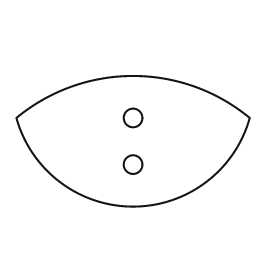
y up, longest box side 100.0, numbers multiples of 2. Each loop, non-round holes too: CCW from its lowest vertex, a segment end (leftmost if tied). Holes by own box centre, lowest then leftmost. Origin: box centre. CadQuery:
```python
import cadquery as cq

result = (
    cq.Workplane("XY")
    .moveTo(-50.0, 10.0)
    .threePointArc((0.0, -28.0), (50.0, 10.0))
    .threePointArc((0.0, 28.0), (-50.0, 10.0))
    .close()
    .moveTo(0.0, -10.0)
    .circle(4.0)
    .moveTo(0.0, 10.0)
    .circle(4.0)
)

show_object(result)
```